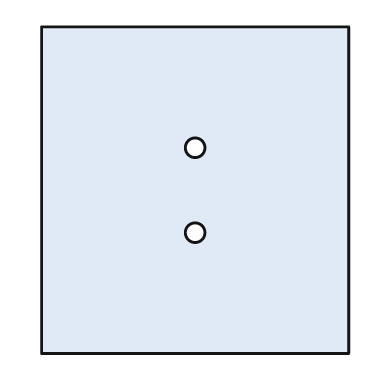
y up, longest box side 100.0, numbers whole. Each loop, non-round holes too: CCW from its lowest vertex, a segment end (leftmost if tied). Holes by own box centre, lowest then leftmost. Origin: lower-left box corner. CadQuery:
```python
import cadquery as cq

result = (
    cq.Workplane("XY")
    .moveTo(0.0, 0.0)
    .lineTo(94.0, 0.0)
    .lineTo(94.0, 100.0)
    .lineTo(0.0, 100.0)
    .close()
    .moveTo(47.0, 37.0)
    .circle(3.0)
    .moveTo(47.0, 63.0)
    .circle(3.0)
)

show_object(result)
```